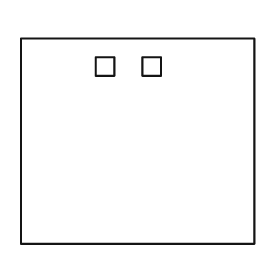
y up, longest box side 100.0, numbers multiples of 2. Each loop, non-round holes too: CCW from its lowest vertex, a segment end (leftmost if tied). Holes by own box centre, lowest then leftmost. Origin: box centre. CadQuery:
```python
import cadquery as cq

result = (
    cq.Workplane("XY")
    .moveTo(-50.0, -44.0)
    .lineTo(50.0, -44.0)
    .lineTo(50.0, 44.0)
    .lineTo(-50.0, 44.0)
    .close()
    .moveTo(-18.0, 28.0)
    .lineTo(-10.0, 28.0)
    .lineTo(-10.0, 36.0)
    .lineTo(-18.0, 36.0)
    .close()
    .moveTo(2.0, 28.0)
    .lineTo(10.0, 28.0)
    .lineTo(10.0, 36.0)
    .lineTo(2.0, 36.0)
    .close()
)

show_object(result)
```